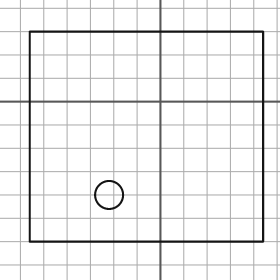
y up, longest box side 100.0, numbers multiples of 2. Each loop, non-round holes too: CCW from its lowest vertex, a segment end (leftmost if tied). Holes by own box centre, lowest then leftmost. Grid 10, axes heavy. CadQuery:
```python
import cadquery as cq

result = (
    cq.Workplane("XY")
    .moveTo(-56.0, -60.0)
    .lineTo(44.0, -60.0)
    .lineTo(44.0, 30.0)
    .lineTo(-56.0, 30.0)
    .close()
    .moveTo(-22.0, -40.0)
    .circle(6.0)
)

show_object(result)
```